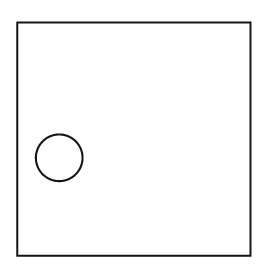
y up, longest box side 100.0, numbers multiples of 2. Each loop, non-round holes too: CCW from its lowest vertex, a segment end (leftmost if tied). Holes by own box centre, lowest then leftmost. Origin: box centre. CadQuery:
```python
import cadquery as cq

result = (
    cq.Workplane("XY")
    .moveTo(-50.0, -50.0)
    .lineTo(50.0, -50.0)
    .lineTo(50.0, 50.0)
    .lineTo(-50.0, 50.0)
    .close()
    .moveTo(-32.0, -8.0)
    .circle(10.0)
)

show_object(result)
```